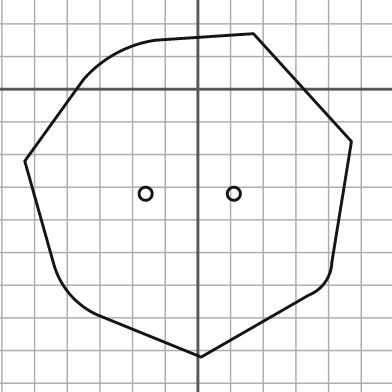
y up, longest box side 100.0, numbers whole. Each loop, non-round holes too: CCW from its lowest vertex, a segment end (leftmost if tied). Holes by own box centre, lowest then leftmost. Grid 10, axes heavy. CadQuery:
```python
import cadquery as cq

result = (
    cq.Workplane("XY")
    .moveTo(1.0, -82.0)
    .lineTo(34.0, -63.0)
    .threePointArc((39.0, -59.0), (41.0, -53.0))
    .lineTo(47.0, -16.0)
    .lineTo(17.0, 17.0)
    .lineTo(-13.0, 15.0)
    .threePointArc((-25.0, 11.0), (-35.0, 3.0))
    .lineTo(-53.0, -22.0)
    .lineTo(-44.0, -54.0)
    .threePointArc((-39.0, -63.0), (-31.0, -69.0))
    .close()
    .moveTo(-16.0, -32.0)
    .circle(2.0)
    .moveTo(11.0, -32.0)
    .circle(2.0)
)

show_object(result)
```